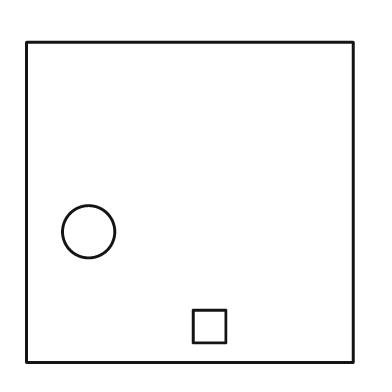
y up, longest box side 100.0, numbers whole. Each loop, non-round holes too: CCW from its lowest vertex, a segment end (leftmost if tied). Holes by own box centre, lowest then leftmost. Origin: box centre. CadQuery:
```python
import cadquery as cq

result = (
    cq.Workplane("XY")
    .moveTo(-50.0, -49.0)
    .lineTo(50.0, -49.0)
    .lineTo(50.0, 49.0)
    .lineTo(-50.0, 49.0)
    .close()
    .moveTo(1.0, -43.0)
    .lineTo(11.0, -43.0)
    .lineTo(11.0, -33.0)
    .lineTo(1.0, -33.0)
    .close()
    .moveTo(-31.0, -9.0)
    .circle(8.0)
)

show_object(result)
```